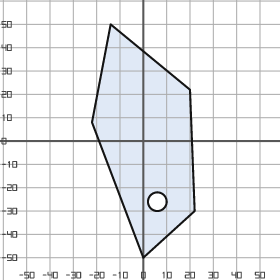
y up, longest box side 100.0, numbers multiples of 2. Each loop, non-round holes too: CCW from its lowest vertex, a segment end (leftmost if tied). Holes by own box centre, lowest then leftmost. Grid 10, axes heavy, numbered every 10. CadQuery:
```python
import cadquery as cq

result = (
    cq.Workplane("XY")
    .moveTo(0.0, -50.0)
    .lineTo(22.0, -30.0)
    .lineTo(20.0, 22.0)
    .lineTo(-14.0, 50.0)
    .lineTo(-22.0, 8.0)
    .close()
    .moveTo(6.0, -26.0)
    .circle(4.0)
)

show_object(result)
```